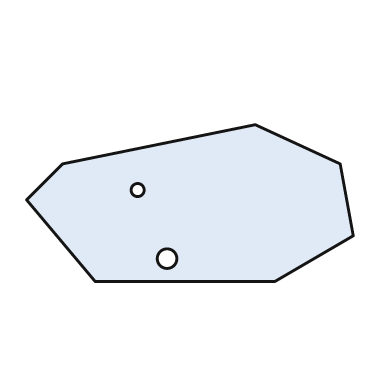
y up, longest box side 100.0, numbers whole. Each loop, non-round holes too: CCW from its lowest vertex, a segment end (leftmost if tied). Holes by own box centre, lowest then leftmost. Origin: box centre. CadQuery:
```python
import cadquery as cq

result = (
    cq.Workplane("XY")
    .moveTo(-29.0, -24.0)
    .lineTo(26.0, -24.0)
    .lineTo(50.0, -10.0)
    .lineTo(46.0, 12.0)
    .lineTo(20.0, 24.0)
    .lineTo(-39.0, 12.0)
    .lineTo(-50.0, 1.0)
    .close()
    .moveTo(-7.0, -17.0)
    .circle(3.0)
    .moveTo(-16.0, 4.0)
    .circle(2.0)
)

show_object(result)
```